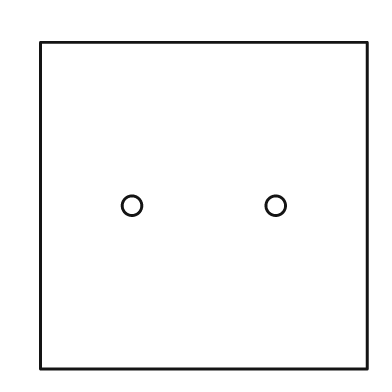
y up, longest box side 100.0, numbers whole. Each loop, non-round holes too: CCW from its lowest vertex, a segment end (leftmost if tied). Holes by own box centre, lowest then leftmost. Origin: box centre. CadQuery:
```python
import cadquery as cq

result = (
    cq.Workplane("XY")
    .moveTo(-50.0, -50.0)
    .lineTo(50.0, -50.0)
    .lineTo(50.0, 50.0)
    .lineTo(-50.0, 50.0)
    .close()
    .moveTo(-22.0, 0.0)
    .circle(3.0)
    .moveTo(22.0, 0.0)
    .circle(3.0)
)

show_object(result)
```